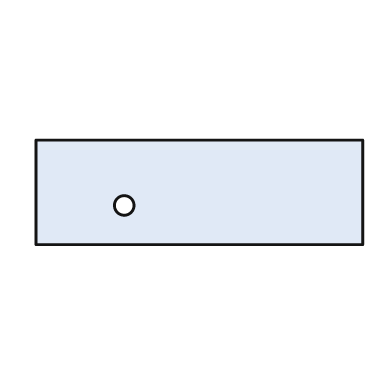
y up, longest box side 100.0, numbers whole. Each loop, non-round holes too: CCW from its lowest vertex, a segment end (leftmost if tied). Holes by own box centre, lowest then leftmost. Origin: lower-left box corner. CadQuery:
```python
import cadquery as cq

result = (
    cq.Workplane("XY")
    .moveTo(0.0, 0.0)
    .lineTo(100.0, 0.0)
    .lineTo(100.0, 32.0)
    .lineTo(0.0, 32.0)
    .close()
    .moveTo(27.0, 12.0)
    .circle(3.0)
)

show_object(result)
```